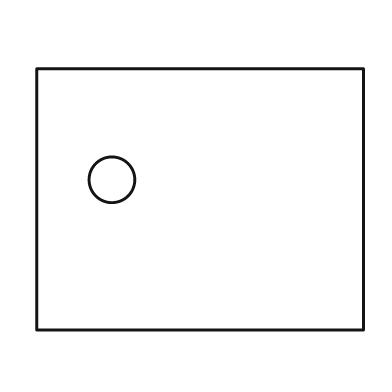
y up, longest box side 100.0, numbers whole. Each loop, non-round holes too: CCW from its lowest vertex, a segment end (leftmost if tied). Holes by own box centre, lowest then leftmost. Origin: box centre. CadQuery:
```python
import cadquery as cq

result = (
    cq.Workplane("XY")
    .moveTo(-50.0, -40.0)
    .lineTo(50.0, -40.0)
    .lineTo(50.0, 40.0)
    .lineTo(-50.0, 40.0)
    .close()
    .moveTo(-27.0, 6.0)
    .circle(7.0)
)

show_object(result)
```